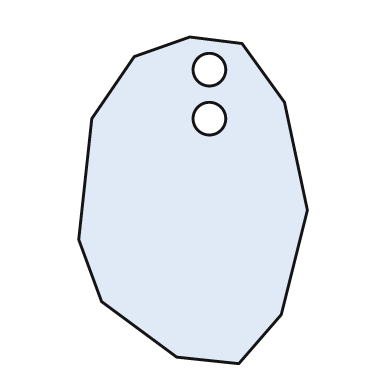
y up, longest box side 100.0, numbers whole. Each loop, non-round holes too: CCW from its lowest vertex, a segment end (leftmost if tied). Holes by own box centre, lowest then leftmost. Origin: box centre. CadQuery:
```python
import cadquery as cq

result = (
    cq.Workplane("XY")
    .moveTo(14.0, -50.0)
    .lineTo(27.0, -35.0)
    .lineTo(35.0, -3.0)
    .lineTo(28.0, 30.0)
    .lineTo(15.0, 48.0)
    .lineTo(-1.0, 50.0)
    .lineTo(-18.0, 44.0)
    .lineTo(-31.0, 25.0)
    .lineTo(-35.0, -12.0)
    .lineTo(-28.0, -31.0)
    .lineTo(-5.0, -48.0)
    .close()
    .moveTo(5.0, 25.0)
    .circle(5.0)
    .moveTo(5.0, 40.0)
    .circle(5.0)
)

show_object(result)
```